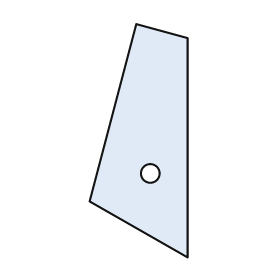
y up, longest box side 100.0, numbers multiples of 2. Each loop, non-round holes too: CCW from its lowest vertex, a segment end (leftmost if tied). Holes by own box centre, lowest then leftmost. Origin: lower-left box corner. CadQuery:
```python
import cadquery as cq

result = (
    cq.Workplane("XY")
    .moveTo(42.0, 0.0)
    .lineTo(42.0, 94.0)
    .lineTo(20.0, 100.0)
    .lineTo(0.0, 24.0)
    .close()
    .moveTo(26.0, 36.0)
    .circle(4.0)
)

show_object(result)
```